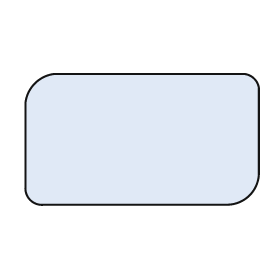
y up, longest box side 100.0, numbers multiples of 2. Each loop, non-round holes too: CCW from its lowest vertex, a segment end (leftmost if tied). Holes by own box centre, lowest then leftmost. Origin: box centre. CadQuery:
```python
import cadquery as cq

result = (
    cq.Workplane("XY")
    .moveTo(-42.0, -28.0)
    .lineTo(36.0, -28.0)
    .threePointArc((46.0, -24.0), (50.0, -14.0))
    .lineTo(50.0, 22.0)
    .threePointArc((48.0, 26.0), (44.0, 28.0))
    .lineTo(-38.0, 28.0)
    .threePointArc((-46.0, 24.0), (-50.0, 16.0))
    .lineTo(-50.0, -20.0)
    .threePointArc((-48.0, -26.0), (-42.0, -28.0))
    .close()
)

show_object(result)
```